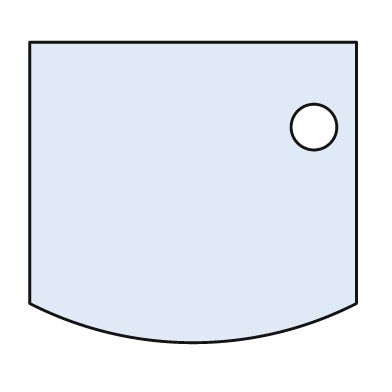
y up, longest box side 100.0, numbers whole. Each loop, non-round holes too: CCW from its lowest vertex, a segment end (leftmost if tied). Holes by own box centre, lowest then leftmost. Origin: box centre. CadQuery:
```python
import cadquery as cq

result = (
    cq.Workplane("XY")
    .moveTo(-50.0, -34.0)
    .threePointArc((0.0, -46.0), (50.0, -34.0))
    .lineTo(50.0, 46.0)
    .lineTo(-50.0, 46.0)
    .close()
    .moveTo(37.0, 20.0)
    .circle(7.0)
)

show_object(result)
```